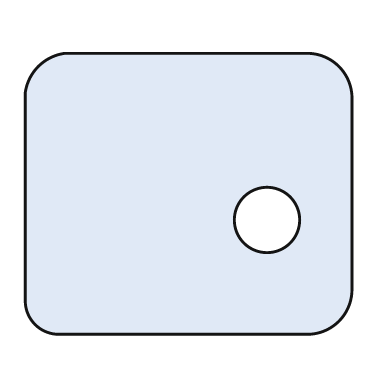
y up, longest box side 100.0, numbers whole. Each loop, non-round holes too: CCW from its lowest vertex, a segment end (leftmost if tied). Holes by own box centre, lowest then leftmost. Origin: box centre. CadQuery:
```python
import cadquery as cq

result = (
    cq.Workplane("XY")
    .moveTo(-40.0, -43.0)
    .lineTo(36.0, -43.0)
    .threePointArc((46.0, -39.0), (50.0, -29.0))
    .lineTo(50.0, 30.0)
    .threePointArc((46.0, 39.0), (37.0, 43.0))
    .lineTo(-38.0, 43.0)
    .threePointArc((-46.0, 39.0), (-50.0, 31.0))
    .lineTo(-50.0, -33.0)
    .threePointArc((-47.0, -40.0), (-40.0, -43.0))
    .close()
    .moveTo(24.0, -8.0)
    .circle(10.0)
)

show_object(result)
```